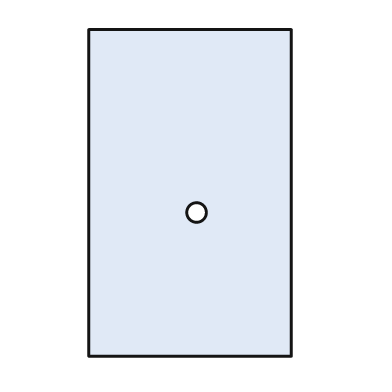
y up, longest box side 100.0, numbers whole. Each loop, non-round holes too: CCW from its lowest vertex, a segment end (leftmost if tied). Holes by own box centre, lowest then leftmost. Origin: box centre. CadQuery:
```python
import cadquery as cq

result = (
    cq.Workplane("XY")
    .moveTo(-31.0, -50.0)
    .lineTo(31.0, -50.0)
    .lineTo(31.0, 50.0)
    .lineTo(-31.0, 50.0)
    .close()
    .moveTo(2.0, -6.0)
    .circle(3.0)
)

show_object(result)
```